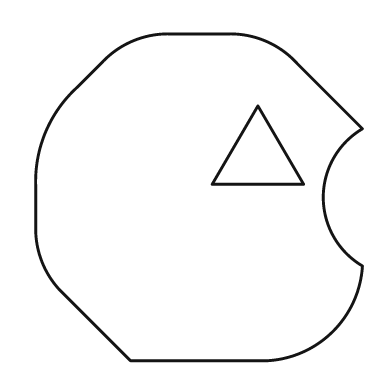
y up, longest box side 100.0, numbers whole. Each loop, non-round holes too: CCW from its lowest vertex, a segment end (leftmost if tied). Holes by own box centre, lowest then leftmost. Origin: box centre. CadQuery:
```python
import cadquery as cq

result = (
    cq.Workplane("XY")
    .moveTo(-21.0, -50.0)
    .lineTo(21.0, -50.0)
    .threePointArc((41.0, -41.0), (50.0, -21.0))
    .threePointArc((38.0, 0.0), (50.0, 21.0))
    .lineTo(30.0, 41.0)
    .threePointArc((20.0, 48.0), (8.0, 50.0))
    .lineTo(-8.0, 50.0)
    .threePointArc((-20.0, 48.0), (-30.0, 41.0))
    .lineTo(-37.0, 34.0)
    .threePointArc((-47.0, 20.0), (-50.0, 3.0))
    .lineTo(-50.0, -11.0)
    .threePointArc((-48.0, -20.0), (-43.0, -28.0))
    .close()
    .moveTo(4.0, 4.0)
    .lineTo(32.0, 4.0)
    .lineTo(18.0, 28.0)
    .close()
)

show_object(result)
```